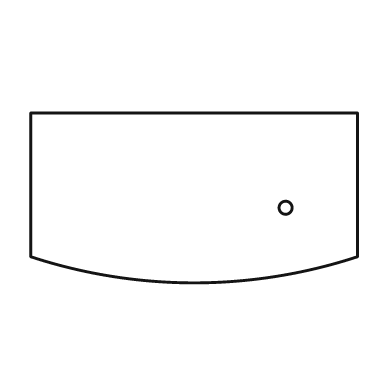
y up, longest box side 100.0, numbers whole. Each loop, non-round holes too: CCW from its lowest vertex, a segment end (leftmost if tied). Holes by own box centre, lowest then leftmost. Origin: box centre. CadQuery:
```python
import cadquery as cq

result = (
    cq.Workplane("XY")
    .moveTo(-50.0, -18.0)
    .threePointArc((0.0, -26.0), (50.0, -18.0))
    .lineTo(50.0, 26.0)
    .lineTo(-50.0, 26.0)
    .close()
    .moveTo(28.0, -3.0)
    .circle(2.0)
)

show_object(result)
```